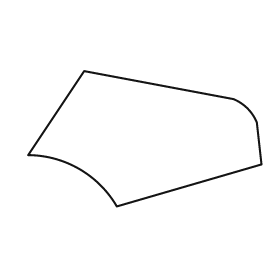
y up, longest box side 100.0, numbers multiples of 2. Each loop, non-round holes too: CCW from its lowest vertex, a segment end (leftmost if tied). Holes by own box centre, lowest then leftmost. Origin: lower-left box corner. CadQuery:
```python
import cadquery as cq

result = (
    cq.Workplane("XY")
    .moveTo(38.0, 0.0)
    .lineTo(100.0, 18.0)
    .lineTo(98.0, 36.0)
    .threePointArc((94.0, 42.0), (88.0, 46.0))
    .lineTo(24.0, 58.0)
    .lineTo(0.0, 22.0)
    .threePointArc((22.0, 16.0), (38.0, 0.0))
    .close()
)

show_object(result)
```